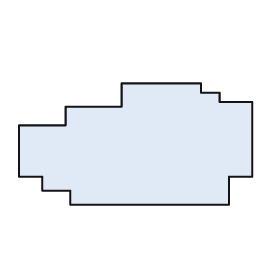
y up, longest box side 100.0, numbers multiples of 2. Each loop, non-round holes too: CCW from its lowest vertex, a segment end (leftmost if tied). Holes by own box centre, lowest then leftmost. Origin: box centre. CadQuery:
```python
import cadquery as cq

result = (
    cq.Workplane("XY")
    .moveTo(-28.0, -26.0)
    .lineTo(40.0, -26.0)
    .lineTo(40.0, -14.0)
    .lineTo(50.0, -14.0)
    .lineTo(50.0, 18.0)
    .lineTo(36.0, 18.0)
    .lineTo(36.0, 22.0)
    .lineTo(28.0, 22.0)
    .lineTo(28.0, 26.0)
    .lineTo(-6.0, 26.0)
    .lineTo(-6.0, 16.0)
    .lineTo(-30.0, 16.0)
    .lineTo(-30.0, 8.0)
    .lineTo(-50.0, 8.0)
    .lineTo(-50.0, -14.0)
    .lineTo(-40.0, -14.0)
    .lineTo(-40.0, -20.0)
    .lineTo(-28.0, -20.0)
    .close()
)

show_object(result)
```